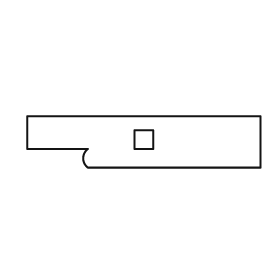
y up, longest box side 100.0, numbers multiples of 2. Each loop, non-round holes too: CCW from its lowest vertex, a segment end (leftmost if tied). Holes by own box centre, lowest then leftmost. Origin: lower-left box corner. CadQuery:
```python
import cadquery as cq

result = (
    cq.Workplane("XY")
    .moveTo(26.0, 0.0)
    .lineTo(100.0, 0.0)
    .lineTo(100.0, 22.0)
    .lineTo(0.0, 22.0)
    .lineTo(0.0, 8.0)
    .lineTo(26.0, 8.0)
    .threePointArc((24.0, 4.0), (26.0, 0.0))
    .close()
    .moveTo(46.0, 8.0)
    .lineTo(54.0, 8.0)
    .lineTo(54.0, 16.0)
    .lineTo(46.0, 16.0)
    .close()
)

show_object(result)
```